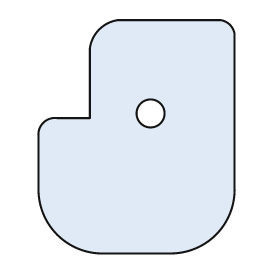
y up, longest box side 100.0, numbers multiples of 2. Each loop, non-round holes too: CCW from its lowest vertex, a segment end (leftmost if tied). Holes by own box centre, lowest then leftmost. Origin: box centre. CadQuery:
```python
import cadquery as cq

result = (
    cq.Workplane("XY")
    .moveTo(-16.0, -50.0)
    .lineTo(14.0, -50.0)
    .threePointArc((34.0, -42.0), (42.0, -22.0))
    .lineTo(42.0, 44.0)
    .threePointArc((40.0, 48.0), (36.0, 50.0))
    .lineTo(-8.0, 50.0)
    .threePointArc((-16.0, 46.0), (-20.0, 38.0))
    .lineTo(-20.0, 8.0)
    .lineTo(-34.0, 8.0)
    .threePointArc((-40.0, 6.0), (-42.0, 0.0))
    .lineTo(-42.0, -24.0)
    .threePointArc((-34.0, -42.0), (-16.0, -50.0))
    .close()
    .moveTo(6.0, 10.0)
    .circle(6.0)
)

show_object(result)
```